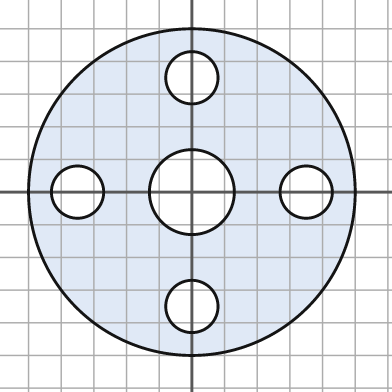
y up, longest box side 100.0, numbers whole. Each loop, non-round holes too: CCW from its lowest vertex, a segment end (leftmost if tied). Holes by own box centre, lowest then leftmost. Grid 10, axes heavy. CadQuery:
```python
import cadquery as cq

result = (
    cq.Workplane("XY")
    .moveTo(0.0, 0.0)
    .circle(50.0)
    .moveTo(0.0, -35.0)
    .circle(8.0)
    .moveTo(-35.0, 0.0)
    .circle(8.0)
    .moveTo(0.0, 0.0)
    .circle(13.0)
    .moveTo(35.0, 0.0)
    .circle(8.0)
    .moveTo(0.0, 35.0)
    .circle(8.0)
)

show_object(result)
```